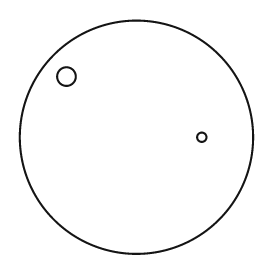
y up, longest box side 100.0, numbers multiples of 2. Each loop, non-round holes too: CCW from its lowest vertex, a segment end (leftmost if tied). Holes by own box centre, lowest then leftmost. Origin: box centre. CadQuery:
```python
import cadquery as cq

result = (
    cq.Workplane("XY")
    .moveTo(0.0, 0.0)
    .circle(50.0)
    .moveTo(28.0, 0.0)
    .circle(2.0)
    .moveTo(-30.0, 26.0)
    .circle(4.0)
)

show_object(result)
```